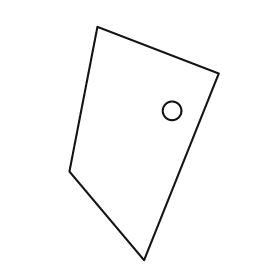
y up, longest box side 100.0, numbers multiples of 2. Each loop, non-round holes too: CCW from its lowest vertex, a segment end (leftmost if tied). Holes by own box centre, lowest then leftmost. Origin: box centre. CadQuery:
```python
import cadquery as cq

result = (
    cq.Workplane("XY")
    .moveTo(0.0, -50.0)
    .lineTo(32.0, 30.0)
    .lineTo(-20.0, 50.0)
    .lineTo(-32.0, -12.0)
    .close()
    .moveTo(12.0, 14.0)
    .circle(4.0)
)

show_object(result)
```